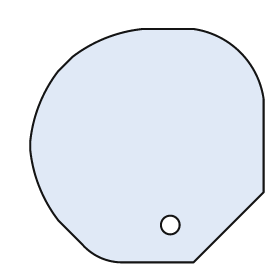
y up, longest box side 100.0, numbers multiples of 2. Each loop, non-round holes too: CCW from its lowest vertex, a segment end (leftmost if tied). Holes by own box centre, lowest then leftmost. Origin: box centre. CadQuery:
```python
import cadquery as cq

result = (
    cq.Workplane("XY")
    .moveTo(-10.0, -50.0)
    .lineTo(20.0, -50.0)
    .lineTo(50.0, -20.0)
    .lineTo(50.0, 20.0)
    .threePointArc((40.0, 40.0), (20.0, 50.0))
    .lineTo(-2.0, 50.0)
    .threePointArc((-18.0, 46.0), (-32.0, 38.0))
    .lineTo(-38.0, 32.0)
    .threePointArc((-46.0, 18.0), (-50.0, 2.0))
    .lineTo(-50.0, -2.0)
    .threePointArc((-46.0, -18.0), (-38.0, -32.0))
    .lineTo(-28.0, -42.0)
    .threePointArc((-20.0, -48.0), (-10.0, -50.0))
    .close()
    .moveTo(10.0, -34.0)
    .circle(4.0)
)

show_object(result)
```